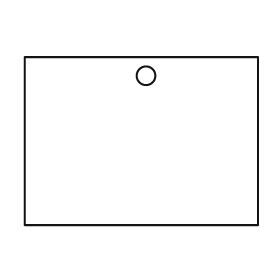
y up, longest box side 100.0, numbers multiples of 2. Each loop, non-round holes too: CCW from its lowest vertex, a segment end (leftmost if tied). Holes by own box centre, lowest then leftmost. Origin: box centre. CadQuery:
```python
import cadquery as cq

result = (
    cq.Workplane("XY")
    .moveTo(-50.0, -36.0)
    .lineTo(50.0, -36.0)
    .lineTo(50.0, 36.0)
    .lineTo(-50.0, 36.0)
    .close()
    .moveTo(2.0, 28.0)
    .circle(4.0)
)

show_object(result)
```